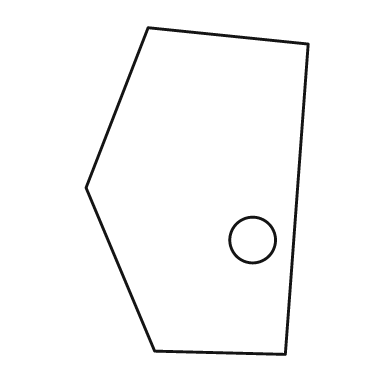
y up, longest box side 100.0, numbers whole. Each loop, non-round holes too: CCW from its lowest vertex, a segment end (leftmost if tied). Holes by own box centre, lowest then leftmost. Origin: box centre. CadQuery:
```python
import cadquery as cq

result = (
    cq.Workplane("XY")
    .moveTo(27.0, -50.0)
    .lineTo(34.0, 45.0)
    .lineTo(-15.0, 50.0)
    .lineTo(-34.0, 1.0)
    .lineTo(-13.0, -49.0)
    .close()
    .moveTo(17.0, -15.0)
    .circle(7.0)
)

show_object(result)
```